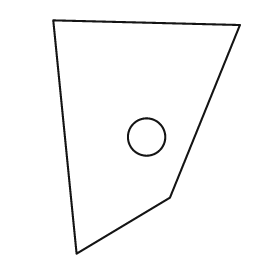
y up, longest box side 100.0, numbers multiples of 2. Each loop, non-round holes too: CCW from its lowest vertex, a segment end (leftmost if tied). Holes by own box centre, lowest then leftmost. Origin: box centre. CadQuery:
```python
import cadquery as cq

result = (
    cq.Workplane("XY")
    .moveTo(-30.0, -50.0)
    .lineTo(10.0, -26.0)
    .lineTo(40.0, 48.0)
    .lineTo(-40.0, 50.0)
    .close()
    .moveTo(0.0, 0.0)
    .circle(8.0)
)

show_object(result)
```